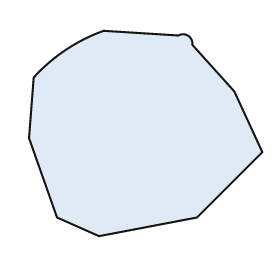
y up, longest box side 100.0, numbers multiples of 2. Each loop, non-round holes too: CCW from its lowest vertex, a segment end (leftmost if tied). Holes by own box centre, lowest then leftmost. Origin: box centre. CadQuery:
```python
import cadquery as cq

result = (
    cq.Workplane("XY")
    .moveTo(-20.0, -44.0)
    .lineTo(22.0, -36.0)
    .lineTo(50.0, -8.0)
    .lineTo(38.0, 18.0)
    .lineTo(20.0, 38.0)
    .threePointArc((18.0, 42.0), (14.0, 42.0))
    .lineTo(-18.0, 44.0)
    .threePointArc((-34.0, 36.0), (-48.0, 24.0))
    .lineTo(-50.0, -2.0)
    .lineTo(-38.0, -36.0)
    .close()
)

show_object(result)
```